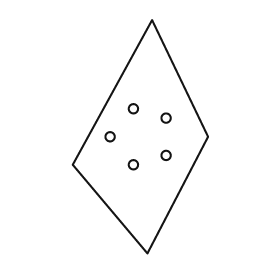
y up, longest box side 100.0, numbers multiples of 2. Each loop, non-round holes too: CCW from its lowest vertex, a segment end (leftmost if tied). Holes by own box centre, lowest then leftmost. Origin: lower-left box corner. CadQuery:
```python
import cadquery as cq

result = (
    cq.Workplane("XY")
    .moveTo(32.0, 0.0)
    .lineTo(58.0, 50.0)
    .lineTo(34.0, 100.0)
    .lineTo(0.0, 38.0)
    .close()
    .moveTo(26.0, 38.0)
    .circle(2.0)
    .moveTo(40.0, 42.0)
    .circle(2.0)
    .moveTo(16.0, 50.0)
    .circle(2.0)
    .moveTo(40.0, 58.0)
    .circle(2.0)
    .moveTo(26.0, 62.0)
    .circle(2.0)
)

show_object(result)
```